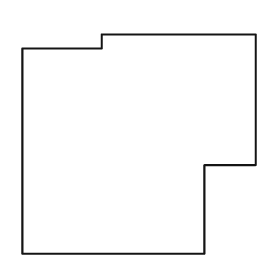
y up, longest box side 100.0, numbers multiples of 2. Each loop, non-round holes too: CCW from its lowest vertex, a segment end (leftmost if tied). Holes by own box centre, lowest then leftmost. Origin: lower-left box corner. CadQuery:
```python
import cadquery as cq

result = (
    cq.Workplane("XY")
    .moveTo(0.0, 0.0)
    .lineTo(78.0, 0.0)
    .lineTo(78.0, 38.0)
    .lineTo(100.0, 38.0)
    .lineTo(100.0, 94.0)
    .lineTo(34.0, 94.0)
    .lineTo(34.0, 88.0)
    .lineTo(0.0, 88.0)
    .close()
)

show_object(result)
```